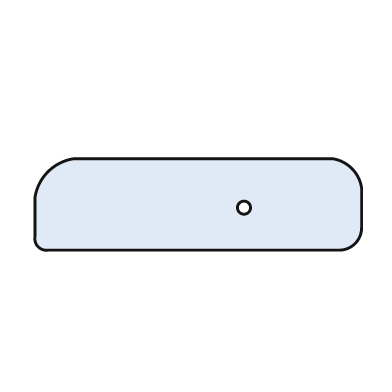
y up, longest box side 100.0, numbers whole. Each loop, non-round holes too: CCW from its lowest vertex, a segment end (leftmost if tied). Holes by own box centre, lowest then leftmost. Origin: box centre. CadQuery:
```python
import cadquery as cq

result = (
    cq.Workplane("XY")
    .moveTo(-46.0, -14.0)
    .lineTo(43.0, -14.0)
    .threePointArc((48.0, -12.0), (50.0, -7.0))
    .lineTo(50.0, 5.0)
    .threePointArc((47.0, 11.0), (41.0, 14.0))
    .lineTo(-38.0, 14.0)
    .threePointArc((-46.0, 10.0), (-50.0, 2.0))
    .lineTo(-50.0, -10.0)
    .threePointArc((-49.0, -13.0), (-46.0, -14.0))
    .close()
    .moveTo(14.0, -1.0)
    .circle(2.0)
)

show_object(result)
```